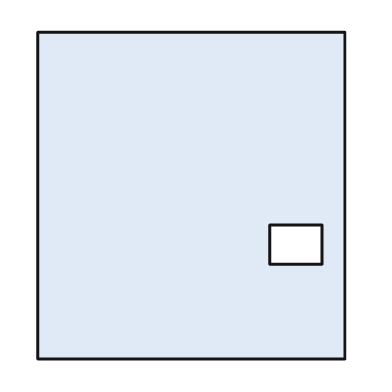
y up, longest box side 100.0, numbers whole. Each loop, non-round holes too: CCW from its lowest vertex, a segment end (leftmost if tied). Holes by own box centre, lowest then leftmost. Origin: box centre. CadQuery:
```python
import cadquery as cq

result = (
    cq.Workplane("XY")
    .moveTo(-47.0, -50.0)
    .lineTo(47.0, -50.0)
    .lineTo(47.0, 50.0)
    .lineTo(-47.0, 50.0)
    .close()
    .moveTo(24.0, -21.0)
    .lineTo(40.0, -21.0)
    .lineTo(40.0, -9.0)
    .lineTo(24.0, -9.0)
    .close()
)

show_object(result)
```